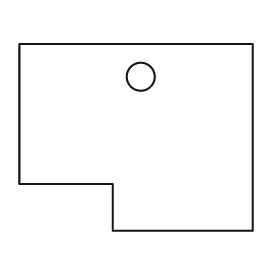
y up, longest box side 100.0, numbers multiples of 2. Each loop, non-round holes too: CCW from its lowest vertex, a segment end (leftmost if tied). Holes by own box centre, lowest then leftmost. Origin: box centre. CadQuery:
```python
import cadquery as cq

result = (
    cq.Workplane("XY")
    .moveTo(-10.0, -40.0)
    .lineTo(50.0, -40.0)
    .lineTo(50.0, 40.0)
    .lineTo(-50.0, 40.0)
    .lineTo(-50.0, -20.0)
    .lineTo(-10.0, -20.0)
    .close()
    .moveTo(2.0, 26.0)
    .circle(6.0)
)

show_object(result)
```